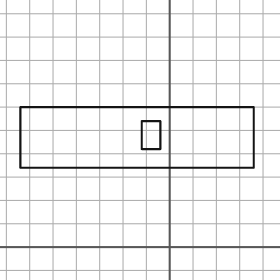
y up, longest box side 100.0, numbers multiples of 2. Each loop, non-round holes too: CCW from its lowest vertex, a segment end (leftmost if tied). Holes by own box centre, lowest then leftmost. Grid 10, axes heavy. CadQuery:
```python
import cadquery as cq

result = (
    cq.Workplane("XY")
    .moveTo(-64.0, 34.0)
    .lineTo(36.0, 34.0)
    .lineTo(36.0, 60.0)
    .lineTo(-64.0, 60.0)
    .close()
    .moveTo(-12.0, 42.0)
    .lineTo(-4.0, 42.0)
    .lineTo(-4.0, 54.0)
    .lineTo(-12.0, 54.0)
    .close()
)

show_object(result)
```